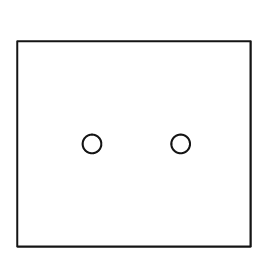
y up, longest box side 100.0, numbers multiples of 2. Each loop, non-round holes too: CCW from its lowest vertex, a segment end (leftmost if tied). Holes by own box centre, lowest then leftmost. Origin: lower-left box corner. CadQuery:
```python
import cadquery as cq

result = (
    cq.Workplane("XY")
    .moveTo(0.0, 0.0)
    .lineTo(100.0, 0.0)
    .lineTo(100.0, 88.0)
    .lineTo(0.0, 88.0)
    .close()
    .moveTo(32.0, 44.0)
    .circle(4.0)
    .moveTo(70.0, 44.0)
    .circle(4.0)
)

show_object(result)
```